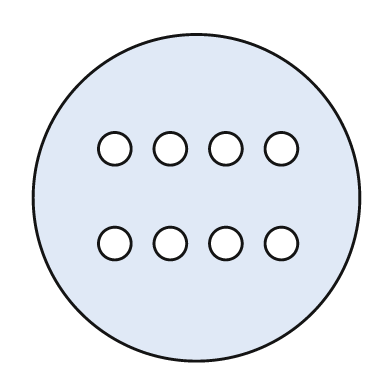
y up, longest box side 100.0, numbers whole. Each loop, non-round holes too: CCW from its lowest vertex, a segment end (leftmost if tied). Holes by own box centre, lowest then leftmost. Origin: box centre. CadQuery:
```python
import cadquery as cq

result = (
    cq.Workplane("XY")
    .moveTo(0.0, 0.0)
    .circle(50.0)
    .moveTo(-25.0, -14.0)
    .circle(5.0)
    .moveTo(-8.0, -14.0)
    .circle(5.0)
    .moveTo(9.0, -14.0)
    .circle(5.0)
    .moveTo(26.0, -14.0)
    .circle(5.0)
    .moveTo(-25.0, 15.0)
    .circle(5.0)
    .moveTo(-8.0, 15.0)
    .circle(5.0)
    .moveTo(9.0, 15.0)
    .circle(5.0)
    .moveTo(26.0, 15.0)
    .circle(5.0)
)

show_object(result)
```